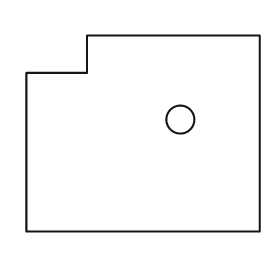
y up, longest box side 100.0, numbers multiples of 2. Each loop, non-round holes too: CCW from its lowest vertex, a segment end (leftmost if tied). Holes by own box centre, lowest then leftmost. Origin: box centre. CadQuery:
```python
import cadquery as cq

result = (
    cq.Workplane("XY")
    .moveTo(-50.0, -42.0)
    .lineTo(50.0, -42.0)
    .lineTo(50.0, 42.0)
    .lineTo(-24.0, 42.0)
    .lineTo(-24.0, 26.0)
    .lineTo(-50.0, 26.0)
    .close()
    .moveTo(16.0, 6.0)
    .circle(6.0)
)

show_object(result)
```